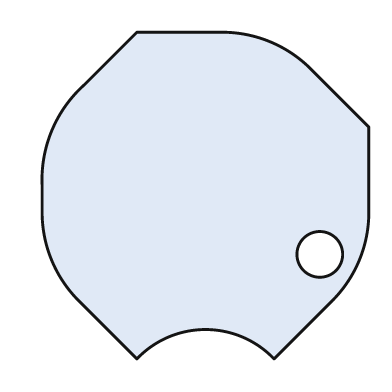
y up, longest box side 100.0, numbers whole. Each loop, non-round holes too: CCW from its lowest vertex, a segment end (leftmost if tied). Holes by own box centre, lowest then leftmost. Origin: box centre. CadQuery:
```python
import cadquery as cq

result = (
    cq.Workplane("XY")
    .moveTo(-21.0, -50.0)
    .threePointArc((0.0, -41.0), (21.0, -50.0))
    .lineTo(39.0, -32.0)
    .threePointArc((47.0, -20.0), (50.0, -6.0))
    .lineTo(50.0, 21.0)
    .lineTo(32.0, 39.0)
    .threePointArc((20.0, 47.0), (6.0, 50.0))
    .lineTo(-21.0, 50.0)
    .lineTo(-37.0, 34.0)
    .threePointArc((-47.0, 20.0), (-50.0, 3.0))
    .lineTo(-50.0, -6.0)
    .threePointArc((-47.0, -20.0), (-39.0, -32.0))
    .close()
    .moveTo(35.0, -18.0)
    .circle(7.0)
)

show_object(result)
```